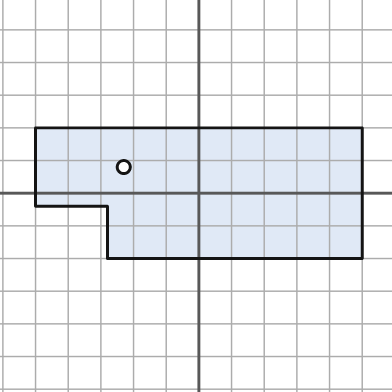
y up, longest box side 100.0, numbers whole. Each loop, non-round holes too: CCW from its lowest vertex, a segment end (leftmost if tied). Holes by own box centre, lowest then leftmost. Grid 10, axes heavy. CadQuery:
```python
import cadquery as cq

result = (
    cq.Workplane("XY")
    .moveTo(-28.0, -20.0)
    .lineTo(50.0, -20.0)
    .lineTo(50.0, 20.0)
    .lineTo(-50.0, 20.0)
    .lineTo(-50.0, -4.0)
    .lineTo(-28.0, -4.0)
    .close()
    .moveTo(-23.0, 8.0)
    .circle(2.0)
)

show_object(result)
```